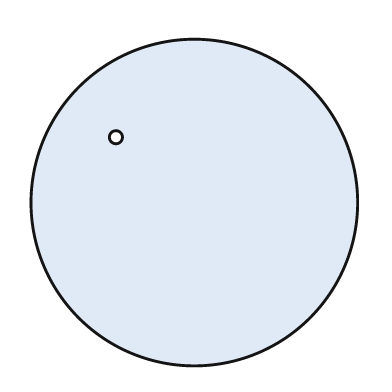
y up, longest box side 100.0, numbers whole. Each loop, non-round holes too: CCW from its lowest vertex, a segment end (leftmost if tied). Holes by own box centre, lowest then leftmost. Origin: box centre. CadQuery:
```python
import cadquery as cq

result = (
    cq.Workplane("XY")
    .moveTo(0.0, 0.0)
    .circle(50.0)
    .moveTo(-24.0, 20.0)
    .circle(2.0)
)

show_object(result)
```